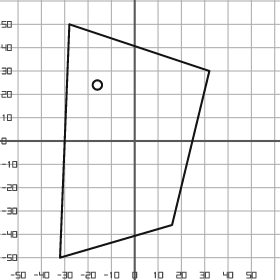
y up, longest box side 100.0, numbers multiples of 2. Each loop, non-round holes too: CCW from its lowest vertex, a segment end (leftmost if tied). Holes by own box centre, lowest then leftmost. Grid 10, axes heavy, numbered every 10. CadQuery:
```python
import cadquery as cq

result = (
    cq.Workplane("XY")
    .moveTo(-32.0, -50.0)
    .lineTo(16.0, -36.0)
    .lineTo(32.0, 30.0)
    .lineTo(-28.0, 50.0)
    .close()
    .moveTo(-16.0, 24.0)
    .circle(2.0)
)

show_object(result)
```